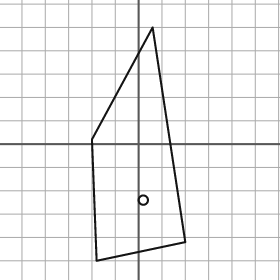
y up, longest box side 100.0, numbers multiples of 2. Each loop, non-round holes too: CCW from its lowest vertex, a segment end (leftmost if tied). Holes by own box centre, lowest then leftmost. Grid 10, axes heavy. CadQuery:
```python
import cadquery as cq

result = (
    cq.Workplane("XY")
    .moveTo(-18.0, -50.0)
    .lineTo(20.0, -42.0)
    .lineTo(6.0, 50.0)
    .lineTo(-20.0, 2.0)
    .close()
    .moveTo(2.0, -24.0)
    .circle(2.0)
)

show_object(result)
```